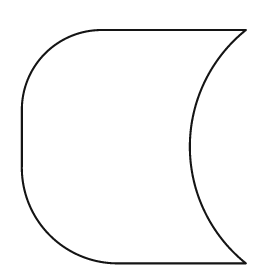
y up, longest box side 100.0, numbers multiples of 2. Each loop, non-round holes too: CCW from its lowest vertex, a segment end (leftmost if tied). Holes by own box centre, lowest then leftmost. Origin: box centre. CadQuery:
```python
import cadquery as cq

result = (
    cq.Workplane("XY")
    .moveTo(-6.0, -50.0)
    .lineTo(48.0, -50.0)
    .threePointArc((24.0, 0.0), (48.0, 50.0))
    .lineTo(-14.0, 50.0)
    .threePointArc((-38.0, 40.0), (-48.0, 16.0))
    .lineTo(-48.0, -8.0)
    .threePointArc((-36.0, -38.0), (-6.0, -50.0))
    .close()
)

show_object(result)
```